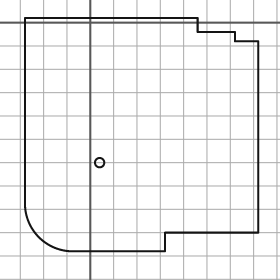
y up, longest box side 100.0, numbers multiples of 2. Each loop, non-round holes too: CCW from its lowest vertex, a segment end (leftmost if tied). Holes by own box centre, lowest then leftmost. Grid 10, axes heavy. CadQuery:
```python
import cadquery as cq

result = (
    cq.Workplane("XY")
    .moveTo(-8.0, -98.0)
    .lineTo(32.0, -98.0)
    .lineTo(32.0, -90.0)
    .lineTo(72.0, -90.0)
    .lineTo(72.0, -8.0)
    .lineTo(62.0, -8.0)
    .lineTo(62.0, -4.0)
    .lineTo(46.0, -4.0)
    .lineTo(46.0, 2.0)
    .lineTo(-28.0, 2.0)
    .lineTo(-28.0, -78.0)
    .threePointArc((-22.0, -92.0), (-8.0, -98.0))
    .close()
    .moveTo(4.0, -60.0)
    .circle(2.0)
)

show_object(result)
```